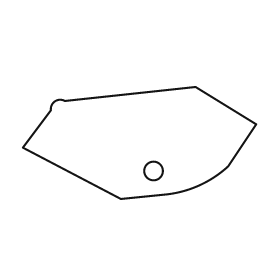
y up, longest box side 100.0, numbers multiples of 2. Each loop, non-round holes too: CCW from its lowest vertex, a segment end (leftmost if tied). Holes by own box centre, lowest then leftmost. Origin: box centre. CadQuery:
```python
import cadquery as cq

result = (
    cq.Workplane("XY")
    .moveTo(-8.0, -24.0)
    .lineTo(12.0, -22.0)
    .threePointArc((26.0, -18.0), (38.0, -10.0))
    .lineTo(50.0, 8.0)
    .lineTo(24.0, 24.0)
    .lineTo(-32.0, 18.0)
    .threePointArc((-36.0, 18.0), (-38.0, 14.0))
    .lineTo(-50.0, -2.0)
    .close()
    .moveTo(6.0, -12.0)
    .circle(4.0)
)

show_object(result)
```